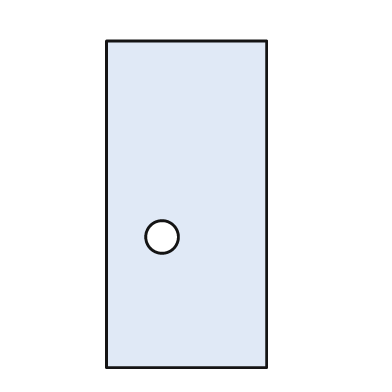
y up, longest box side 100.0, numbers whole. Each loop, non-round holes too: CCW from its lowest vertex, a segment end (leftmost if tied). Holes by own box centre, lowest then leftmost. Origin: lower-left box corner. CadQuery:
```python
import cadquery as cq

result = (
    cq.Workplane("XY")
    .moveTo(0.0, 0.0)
    .lineTo(49.0, 0.0)
    .lineTo(49.0, 100.0)
    .lineTo(0.0, 100.0)
    .close()
    .moveTo(17.0, 40.0)
    .circle(5.0)
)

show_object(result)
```